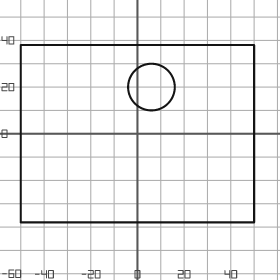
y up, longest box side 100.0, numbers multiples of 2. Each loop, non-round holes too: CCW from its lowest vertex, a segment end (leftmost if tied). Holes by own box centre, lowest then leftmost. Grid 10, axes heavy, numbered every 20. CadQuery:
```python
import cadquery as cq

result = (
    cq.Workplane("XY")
    .moveTo(-50.0, -38.0)
    .lineTo(50.0, -38.0)
    .lineTo(50.0, 38.0)
    .lineTo(-50.0, 38.0)
    .close()
    .moveTo(6.0, 20.0)
    .circle(10.0)
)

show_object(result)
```